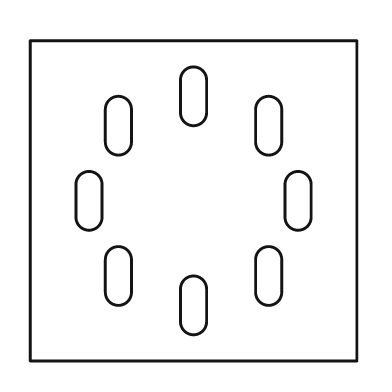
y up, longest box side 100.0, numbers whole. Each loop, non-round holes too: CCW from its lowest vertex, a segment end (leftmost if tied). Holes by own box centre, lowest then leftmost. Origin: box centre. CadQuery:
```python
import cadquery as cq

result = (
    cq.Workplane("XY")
    .moveTo(-50.0, -49.0)
    .lineTo(50.0, -49.0)
    .lineTo(50.0, 49.0)
    .lineTo(-50.0, 49.0)
    .close()
    .moveTo(-4.0, -37.0)
    .threePointArc((0.0, -41.0), (4.0, -37.0))
    .lineTo(4.0, -27.0)
    .threePointArc((0.0, -23.0), (-4.0, -27.0))
    .close()
    .moveTo(-27.0, -28.0)
    .threePointArc((-23.0, -32.0), (-19.0, -28.0))
    .lineTo(-19.0, -18.0)
    .threePointArc((-23.0, -14.0), (-27.0, -18.0))
    .close()
    .moveTo(19.0, -28.0)
    .threePointArc((23.0, -32.0), (27.0, -28.0))
    .lineTo(27.0, -18.0)
    .threePointArc((23.0, -14.0), (19.0, -18.0))
    .close()
    .moveTo(-36.0, -5.0)
    .threePointArc((-32.0, -9.0), (-28.0, -5.0))
    .lineTo(-28.0, 5.0)
    .threePointArc((-32.0, 9.0), (-36.0, 5.0))
    .close()
    .moveTo(28.0, -5.0)
    .threePointArc((32.0, -9.0), (36.0, -5.0))
    .lineTo(36.0, 5.0)
    .threePointArc((32.0, 9.0), (28.0, 5.0))
    .close()
    .moveTo(-27.0, 18.0)
    .threePointArc((-23.0, 14.0), (-19.0, 18.0))
    .lineTo(-19.0, 28.0)
    .threePointArc((-23.0, 32.0), (-27.0, 28.0))
    .close()
    .moveTo(19.0, 18.0)
    .threePointArc((23.0, 14.0), (27.0, 18.0))
    .lineTo(27.0, 28.0)
    .threePointArc((23.0, 32.0), (19.0, 28.0))
    .close()
    .moveTo(-4.0, 27.0)
    .threePointArc((0.0, 23.0), (4.0, 27.0))
    .lineTo(4.0, 37.0)
    .threePointArc((0.0, 41.0), (-4.0, 37.0))
    .close()
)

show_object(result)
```